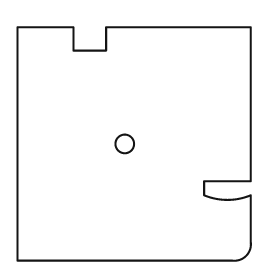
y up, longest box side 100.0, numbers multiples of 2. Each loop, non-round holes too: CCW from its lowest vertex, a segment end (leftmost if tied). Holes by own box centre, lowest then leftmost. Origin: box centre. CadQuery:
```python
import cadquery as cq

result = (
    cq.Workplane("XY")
    .moveTo(-50.0, -50.0)
    .lineTo(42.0, -50.0)
    .threePointArc((48.0, -48.0), (50.0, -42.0))
    .lineTo(50.0, -22.0)
    .threePointArc((40.0, -24.0), (30.0, -22.0))
    .lineTo(30.0, -16.0)
    .lineTo(50.0, -16.0)
    .lineTo(50.0, 50.0)
    .lineTo(-12.0, 50.0)
    .lineTo(-12.0, 40.0)
    .lineTo(-26.0, 40.0)
    .lineTo(-26.0, 50.0)
    .lineTo(-50.0, 50.0)
    .close()
    .moveTo(-4.0, 0.0)
    .circle(4.0)
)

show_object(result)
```